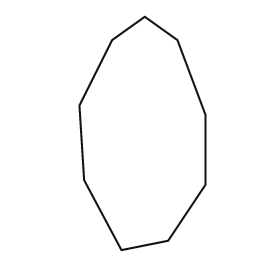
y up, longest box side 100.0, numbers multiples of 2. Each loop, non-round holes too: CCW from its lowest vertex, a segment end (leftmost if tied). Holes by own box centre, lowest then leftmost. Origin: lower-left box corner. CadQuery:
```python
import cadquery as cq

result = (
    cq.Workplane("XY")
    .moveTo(18.0, 0.0)
    .lineTo(38.0, 4.0)
    .lineTo(54.0, 28.0)
    .lineTo(54.0, 58.0)
    .lineTo(42.0, 90.0)
    .lineTo(28.0, 100.0)
    .lineTo(14.0, 90.0)
    .lineTo(0.0, 62.0)
    .lineTo(2.0, 30.0)
    .close()
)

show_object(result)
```